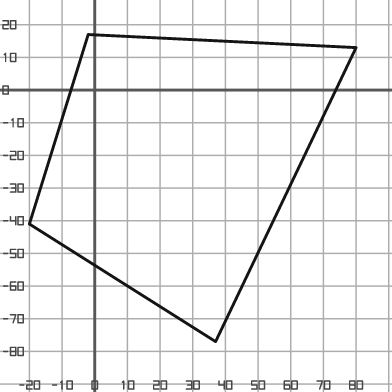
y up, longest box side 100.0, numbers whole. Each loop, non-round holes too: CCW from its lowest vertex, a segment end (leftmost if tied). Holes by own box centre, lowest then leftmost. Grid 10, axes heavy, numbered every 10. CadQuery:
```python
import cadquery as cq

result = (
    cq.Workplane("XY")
    .moveTo(37.0, -77.0)
    .lineTo(80.0, 13.0)
    .lineTo(-2.0, 17.0)
    .lineTo(-20.0, -41.0)
    .close()
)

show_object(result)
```